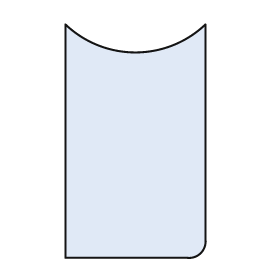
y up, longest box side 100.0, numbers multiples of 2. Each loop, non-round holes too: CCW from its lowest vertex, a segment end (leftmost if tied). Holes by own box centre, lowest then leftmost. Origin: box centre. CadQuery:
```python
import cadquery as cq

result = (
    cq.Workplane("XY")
    .moveTo(-30.0, -50.0)
    .lineTo(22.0, -50.0)
    .threePointArc((28.0, -48.0), (30.0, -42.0))
    .lineTo(30.0, 50.0)
    .threePointArc((0.0, 38.0), (-30.0, 50.0))
    .close()
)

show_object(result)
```